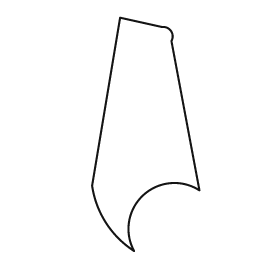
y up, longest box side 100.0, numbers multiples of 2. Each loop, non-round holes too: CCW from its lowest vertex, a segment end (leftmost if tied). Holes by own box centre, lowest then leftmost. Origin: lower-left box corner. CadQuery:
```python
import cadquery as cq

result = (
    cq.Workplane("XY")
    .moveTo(18.0, 0.0)
    .threePointArc((22.0, 24.0), (46.0, 26.0))
    .lineTo(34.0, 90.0)
    .threePointArc((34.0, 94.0), (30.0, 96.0))
    .lineTo(12.0, 100.0)
    .lineTo(0.0, 28.0)
    .threePointArc((6.0, 12.0), (18.0, 0.0))
    .close()
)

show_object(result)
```